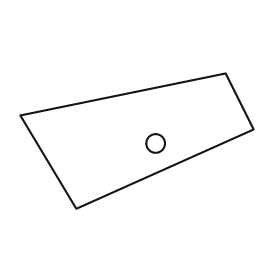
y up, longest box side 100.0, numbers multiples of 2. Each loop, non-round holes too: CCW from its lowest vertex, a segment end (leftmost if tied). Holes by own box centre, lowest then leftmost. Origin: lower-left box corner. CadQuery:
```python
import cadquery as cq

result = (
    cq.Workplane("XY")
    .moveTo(24.0, 0.0)
    .lineTo(100.0, 34.0)
    .lineTo(88.0, 58.0)
    .lineTo(0.0, 40.0)
    .close()
    .moveTo(58.0, 28.0)
    .circle(4.0)
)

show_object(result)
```